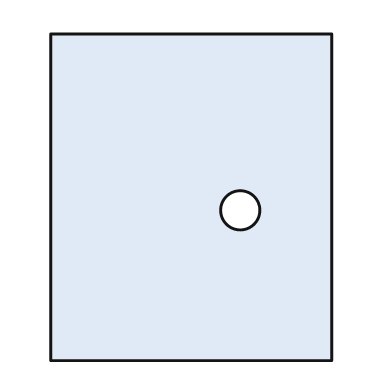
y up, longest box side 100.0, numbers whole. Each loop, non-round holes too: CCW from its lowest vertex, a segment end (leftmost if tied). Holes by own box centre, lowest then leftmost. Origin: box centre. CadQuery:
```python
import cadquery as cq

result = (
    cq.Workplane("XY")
    .moveTo(-43.0, -50.0)
    .lineTo(43.0, -50.0)
    .lineTo(43.0, 50.0)
    .lineTo(-43.0, 50.0)
    .close()
    .moveTo(15.0, -4.0)
    .circle(6.0)
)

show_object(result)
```